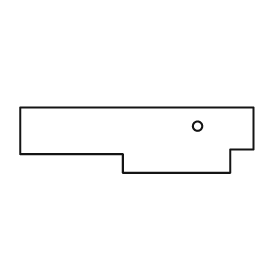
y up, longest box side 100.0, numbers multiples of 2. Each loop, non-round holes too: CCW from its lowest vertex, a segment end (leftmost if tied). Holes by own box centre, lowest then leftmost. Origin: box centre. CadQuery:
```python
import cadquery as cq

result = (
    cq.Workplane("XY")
    .moveTo(-6.0, -14.0)
    .lineTo(40.0, -14.0)
    .lineTo(40.0, -4.0)
    .lineTo(50.0, -4.0)
    .lineTo(50.0, 14.0)
    .lineTo(-50.0, 14.0)
    .lineTo(-50.0, -6.0)
    .lineTo(-6.0, -6.0)
    .close()
    .moveTo(26.0, 6.0)
    .circle(2.0)
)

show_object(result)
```